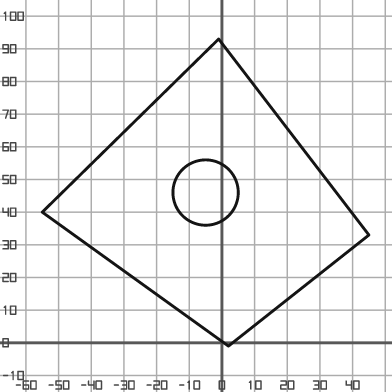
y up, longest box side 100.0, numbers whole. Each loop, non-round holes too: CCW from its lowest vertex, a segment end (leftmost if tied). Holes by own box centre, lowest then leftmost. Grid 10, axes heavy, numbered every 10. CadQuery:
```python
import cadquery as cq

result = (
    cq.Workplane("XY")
    .moveTo(2.0, -1.0)
    .lineTo(45.0, 33.0)
    .lineTo(-1.0, 93.0)
    .lineTo(-55.0, 40.0)
    .close()
    .moveTo(-5.0, 46.0)
    .circle(10.0)
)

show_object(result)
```